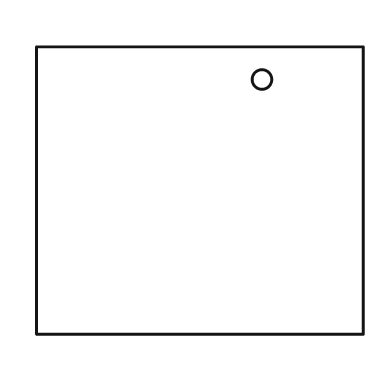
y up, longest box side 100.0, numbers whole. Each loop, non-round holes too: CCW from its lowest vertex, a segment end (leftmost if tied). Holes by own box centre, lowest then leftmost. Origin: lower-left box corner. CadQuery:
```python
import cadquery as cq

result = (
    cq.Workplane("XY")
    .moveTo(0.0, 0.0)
    .lineTo(100.0, 0.0)
    .lineTo(100.0, 88.0)
    .lineTo(0.0, 88.0)
    .close()
    .moveTo(69.0, 78.0)
    .circle(3.0)
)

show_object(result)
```